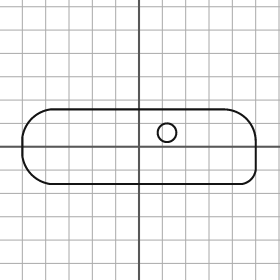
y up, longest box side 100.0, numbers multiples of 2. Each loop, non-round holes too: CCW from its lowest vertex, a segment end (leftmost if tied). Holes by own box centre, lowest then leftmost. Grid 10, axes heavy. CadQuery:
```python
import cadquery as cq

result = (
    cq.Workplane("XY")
    .moveTo(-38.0, -16.0)
    .lineTo(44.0, -16.0)
    .threePointArc((48.0, -14.0), (50.0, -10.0))
    .lineTo(50.0, 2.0)
    .threePointArc((46.0, 12.0), (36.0, 16.0))
    .lineTo(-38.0, 16.0)
    .threePointArc((-46.0, 12.0), (-50.0, 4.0))
    .lineTo(-50.0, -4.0)
    .threePointArc((-46.0, -12.0), (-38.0, -16.0))
    .close()
    .moveTo(12.0, 6.0)
    .circle(4.0)
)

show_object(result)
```